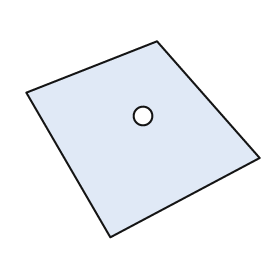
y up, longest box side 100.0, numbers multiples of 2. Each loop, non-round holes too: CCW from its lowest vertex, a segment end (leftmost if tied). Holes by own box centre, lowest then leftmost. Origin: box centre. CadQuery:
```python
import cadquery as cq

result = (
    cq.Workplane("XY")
    .moveTo(-14.0, -42.0)
    .lineTo(50.0, -8.0)
    .lineTo(6.0, 42.0)
    .lineTo(-50.0, 20.0)
    .close()
    .moveTo(0.0, 10.0)
    .circle(4.0)
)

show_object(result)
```